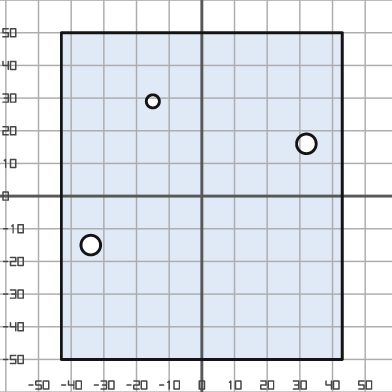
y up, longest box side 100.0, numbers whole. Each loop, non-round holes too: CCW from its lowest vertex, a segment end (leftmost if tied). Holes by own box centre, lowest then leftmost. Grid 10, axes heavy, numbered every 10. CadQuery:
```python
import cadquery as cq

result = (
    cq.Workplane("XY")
    .moveTo(-43.0, -50.0)
    .lineTo(43.0, -50.0)
    .lineTo(43.0, 50.0)
    .lineTo(-43.0, 50.0)
    .close()
    .moveTo(-34.0, -15.0)
    .circle(3.0)
    .moveTo(32.0, 16.0)
    .circle(3.0)
    .moveTo(-15.0, 29.0)
    .circle(2.0)
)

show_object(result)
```